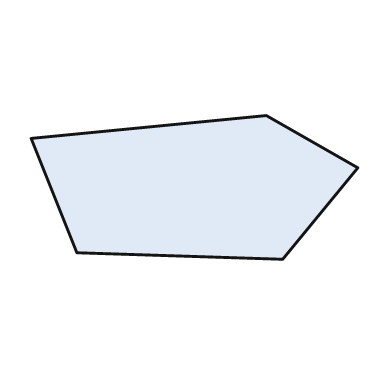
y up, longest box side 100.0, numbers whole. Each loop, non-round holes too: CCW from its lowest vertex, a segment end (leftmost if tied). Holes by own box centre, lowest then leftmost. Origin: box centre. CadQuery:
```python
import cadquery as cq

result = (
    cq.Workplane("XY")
    .moveTo(27.0, -22.0)
    .lineTo(50.0, 6.0)
    .lineTo(22.0, 22.0)
    .lineTo(-50.0, 15.0)
    .lineTo(-36.0, -20.0)
    .close()
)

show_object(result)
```